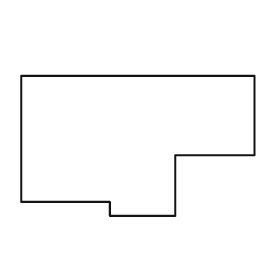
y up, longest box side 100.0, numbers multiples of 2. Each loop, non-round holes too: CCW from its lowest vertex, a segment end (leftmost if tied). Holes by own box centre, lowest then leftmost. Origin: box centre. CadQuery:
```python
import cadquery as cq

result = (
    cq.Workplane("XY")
    .moveTo(-12.0, -30.0)
    .lineTo(16.0, -30.0)
    .lineTo(16.0, -4.0)
    .lineTo(50.0, -4.0)
    .lineTo(50.0, 30.0)
    .lineTo(-50.0, 30.0)
    .lineTo(-50.0, -24.0)
    .lineTo(-12.0, -24.0)
    .close()
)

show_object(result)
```